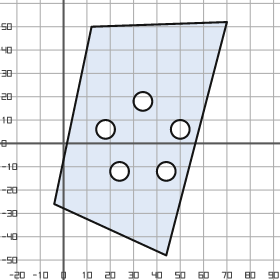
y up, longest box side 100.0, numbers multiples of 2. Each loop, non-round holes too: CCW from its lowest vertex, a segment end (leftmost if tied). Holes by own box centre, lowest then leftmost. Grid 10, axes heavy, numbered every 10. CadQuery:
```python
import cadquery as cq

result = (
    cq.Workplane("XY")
    .moveTo(44.0, -48.0)
    .lineTo(70.0, 52.0)
    .lineTo(12.0, 50.0)
    .lineTo(-4.0, -26.0)
    .close()
    .moveTo(24.0, -12.0)
    .circle(4.0)
    .moveTo(44.0, -12.0)
    .circle(4.0)
    .moveTo(18.0, 6.0)
    .circle(4.0)
    .moveTo(50.0, 6.0)
    .circle(4.0)
    .moveTo(34.0, 18.0)
    .circle(4.0)
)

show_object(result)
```